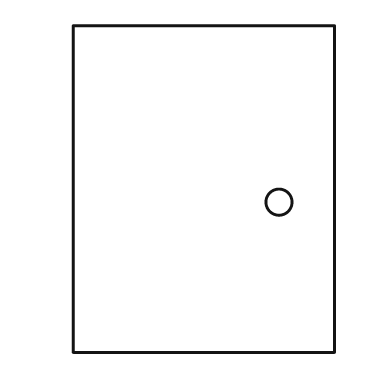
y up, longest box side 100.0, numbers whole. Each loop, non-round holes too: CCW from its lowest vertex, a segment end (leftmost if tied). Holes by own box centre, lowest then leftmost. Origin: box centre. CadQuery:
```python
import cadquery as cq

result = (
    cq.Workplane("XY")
    .moveTo(-40.0, -50.0)
    .lineTo(40.0, -50.0)
    .lineTo(40.0, 50.0)
    .lineTo(-40.0, 50.0)
    .close()
    .moveTo(23.0, -4.0)
    .circle(4.0)
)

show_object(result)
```